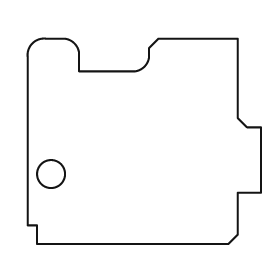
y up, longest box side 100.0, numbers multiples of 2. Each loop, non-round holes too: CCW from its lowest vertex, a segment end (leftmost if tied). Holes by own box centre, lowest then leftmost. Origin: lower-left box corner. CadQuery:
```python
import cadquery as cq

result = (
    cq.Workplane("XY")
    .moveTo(4.0, 0.0)
    .lineTo(86.0, 0.0)
    .lineTo(90.0, 4.0)
    .lineTo(90.0, 22.0)
    .lineTo(100.0, 22.0)
    .lineTo(100.0, 50.0)
    .lineTo(94.0, 50.0)
    .lineTo(90.0, 54.0)
    .lineTo(90.0, 88.0)
    .lineTo(56.0, 88.0)
    .lineTo(52.0, 84.0)
    .lineTo(52.0, 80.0)
    .threePointArc((50.0, 76.0), (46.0, 74.0))
    .lineTo(22.0, 74.0)
    .lineTo(22.0, 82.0)
    .threePointArc((20.0, 86.0), (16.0, 88.0))
    .lineTo(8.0, 88.0)
    .threePointArc((2.0, 86.0), (0.0, 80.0))
    .lineTo(0.0, 8.0)
    .lineTo(4.0, 8.0)
    .close()
    .moveTo(10.0, 30.0)
    .circle(6.0)
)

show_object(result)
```